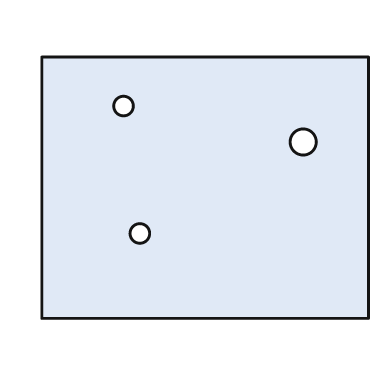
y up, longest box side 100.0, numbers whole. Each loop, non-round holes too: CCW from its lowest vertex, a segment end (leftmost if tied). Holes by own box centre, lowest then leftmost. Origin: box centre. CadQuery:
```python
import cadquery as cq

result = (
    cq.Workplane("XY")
    .moveTo(-50.0, -40.0)
    .lineTo(50.0, -40.0)
    .lineTo(50.0, 40.0)
    .lineTo(-50.0, 40.0)
    .close()
    .moveTo(-20.0, -14.0)
    .circle(3.0)
    .moveTo(30.0, 14.0)
    .circle(4.0)
    .moveTo(-25.0, 25.0)
    .circle(3.0)
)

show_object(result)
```